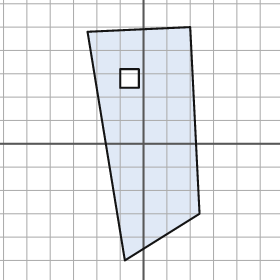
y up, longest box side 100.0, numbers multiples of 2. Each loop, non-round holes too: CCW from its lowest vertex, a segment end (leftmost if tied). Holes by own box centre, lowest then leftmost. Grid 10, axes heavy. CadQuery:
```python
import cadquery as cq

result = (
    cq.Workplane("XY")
    .moveTo(-8.0, -50.0)
    .lineTo(24.0, -30.0)
    .lineTo(20.0, 50.0)
    .lineTo(-24.0, 48.0)
    .close()
    .moveTo(-10.0, 24.0)
    .lineTo(-2.0, 24.0)
    .lineTo(-2.0, 32.0)
    .lineTo(-10.0, 32.0)
    .close()
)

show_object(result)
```